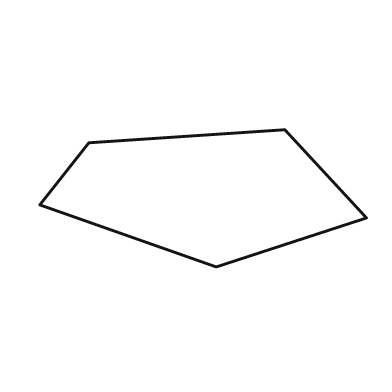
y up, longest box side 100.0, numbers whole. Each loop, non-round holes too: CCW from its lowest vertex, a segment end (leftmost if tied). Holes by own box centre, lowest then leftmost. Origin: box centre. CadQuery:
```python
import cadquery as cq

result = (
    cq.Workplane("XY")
    .moveTo(4.0, -21.0)
    .lineTo(50.0, -6.0)
    .lineTo(25.0, 21.0)
    .lineTo(-35.0, 17.0)
    .lineTo(-50.0, -2.0)
    .close()
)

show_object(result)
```